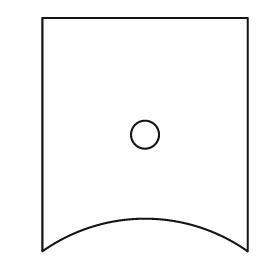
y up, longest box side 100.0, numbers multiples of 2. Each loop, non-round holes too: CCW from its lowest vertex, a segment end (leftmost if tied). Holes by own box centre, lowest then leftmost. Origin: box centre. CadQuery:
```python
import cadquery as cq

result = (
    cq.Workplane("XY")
    .moveTo(-44.0, -50.0)
    .threePointArc((0.0, -36.0), (44.0, -50.0))
    .lineTo(44.0, 50.0)
    .lineTo(-44.0, 50.0)
    .close()
    .moveTo(0.0, 0.0)
    .circle(6.0)
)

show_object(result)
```